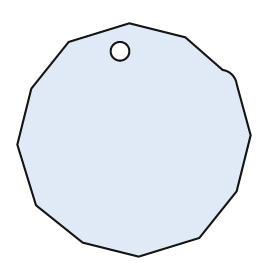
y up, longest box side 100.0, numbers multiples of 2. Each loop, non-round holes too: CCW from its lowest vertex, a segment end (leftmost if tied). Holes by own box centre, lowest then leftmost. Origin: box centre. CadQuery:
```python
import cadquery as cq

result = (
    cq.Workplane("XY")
    .moveTo(2.0, -50.0)
    .lineTo(28.0, -42.0)
    .lineTo(44.0, -22.0)
    .lineTo(50.0, 2.0)
    .lineTo(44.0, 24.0)
    .threePointArc((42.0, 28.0), (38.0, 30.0))
    .lineTo(22.0, 44.0)
    .lineTo(-2.0, 50.0)
    .lineTo(-28.0, 42.0)
    .lineTo(-44.0, 22.0)
    .lineTo(-50.0, -2.0)
    .lineTo(-42.0, -28.0)
    .lineTo(-22.0, -44.0)
    .close()
    .moveTo(-6.0, 38.0)
    .circle(4.0)
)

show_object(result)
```